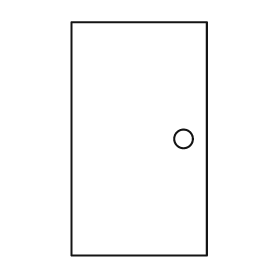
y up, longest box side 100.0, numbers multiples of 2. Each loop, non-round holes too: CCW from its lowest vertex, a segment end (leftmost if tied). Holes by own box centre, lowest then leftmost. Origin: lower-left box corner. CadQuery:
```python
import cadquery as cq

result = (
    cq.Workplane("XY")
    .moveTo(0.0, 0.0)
    .lineTo(58.0, 0.0)
    .lineTo(58.0, 100.0)
    .lineTo(0.0, 100.0)
    .close()
    .moveTo(48.0, 50.0)
    .circle(4.0)
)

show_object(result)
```